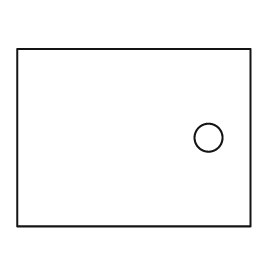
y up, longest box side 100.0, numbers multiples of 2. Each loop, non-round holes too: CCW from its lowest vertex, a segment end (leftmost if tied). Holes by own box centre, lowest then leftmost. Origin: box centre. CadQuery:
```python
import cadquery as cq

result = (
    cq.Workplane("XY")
    .moveTo(-50.0, -38.0)
    .lineTo(50.0, -38.0)
    .lineTo(50.0, 38.0)
    .lineTo(-50.0, 38.0)
    .close()
    .moveTo(32.0, 0.0)
    .circle(6.0)
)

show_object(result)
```